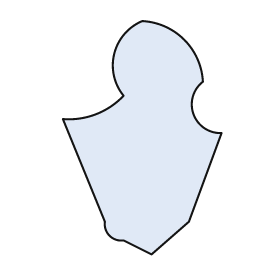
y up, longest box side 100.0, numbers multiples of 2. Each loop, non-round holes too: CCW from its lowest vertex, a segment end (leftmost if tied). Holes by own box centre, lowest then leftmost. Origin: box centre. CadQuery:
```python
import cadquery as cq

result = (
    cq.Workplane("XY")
    .moveTo(4.0, -50.0)
    .lineTo(20.0, -36.0)
    .lineTo(34.0, 2.0)
    .threePointArc((22.0, 10.0), (26.0, 24.0))
    .threePointArc((18.0, 42.0), (0.0, 50.0))
    .threePointArc((-12.0, 36.0), (-8.0, 18.0))
    .threePointArc((-20.0, 10.0), (-34.0, 8.0))
    .lineTo(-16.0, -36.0)
    .threePointArc((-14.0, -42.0), (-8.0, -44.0))
    .close()
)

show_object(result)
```